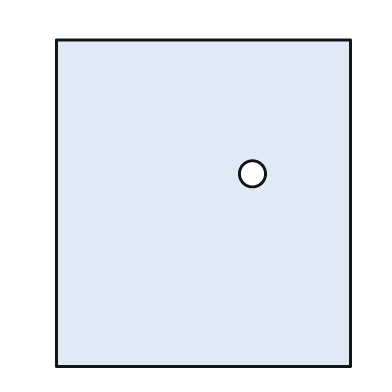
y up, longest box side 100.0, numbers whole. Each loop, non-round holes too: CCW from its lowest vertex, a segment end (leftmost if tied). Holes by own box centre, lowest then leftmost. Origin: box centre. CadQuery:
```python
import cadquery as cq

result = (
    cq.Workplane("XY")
    .moveTo(-45.0, -50.0)
    .lineTo(45.0, -50.0)
    .lineTo(45.0, 50.0)
    .lineTo(-45.0, 50.0)
    .close()
    .moveTo(15.0, 9.0)
    .circle(4.0)
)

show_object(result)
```